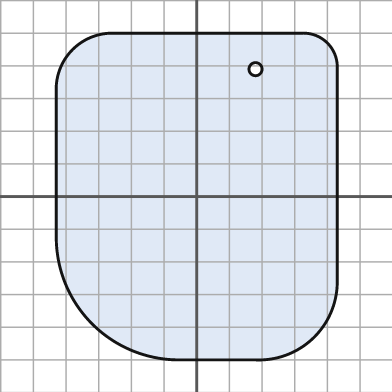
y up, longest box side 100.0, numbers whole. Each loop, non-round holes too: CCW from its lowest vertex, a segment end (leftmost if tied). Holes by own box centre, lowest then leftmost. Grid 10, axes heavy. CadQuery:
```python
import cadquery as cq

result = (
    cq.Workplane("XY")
    .moveTo(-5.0, -50.0)
    .lineTo(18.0, -50.0)
    .threePointArc((36.0, -43.0), (43.0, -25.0))
    .lineTo(43.0, 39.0)
    .threePointArc((40.0, 47.0), (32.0, 50.0))
    .lineTo(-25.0, 50.0)
    .threePointArc((-38.0, 45.0), (-43.0, 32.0))
    .lineTo(-43.0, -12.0)
    .threePointArc((-32.0, -39.0), (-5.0, -50.0))
    .close()
    .moveTo(18.0, 39.0)
    .circle(2.0)
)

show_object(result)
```